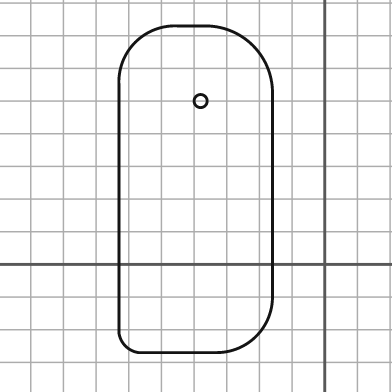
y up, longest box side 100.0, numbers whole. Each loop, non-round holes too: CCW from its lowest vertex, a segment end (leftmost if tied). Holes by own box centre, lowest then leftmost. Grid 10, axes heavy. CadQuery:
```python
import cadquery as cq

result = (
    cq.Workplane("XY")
    .moveTo(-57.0, -27.0)
    .lineTo(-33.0, -27.0)
    .threePointArc((-21.0, -22.0), (-16.0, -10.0))
    .lineTo(-16.0, 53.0)
    .threePointArc((-22.0, 67.0), (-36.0, 73.0))
    .lineTo(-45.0, 73.0)
    .threePointArc((-58.0, 68.0), (-63.0, 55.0))
    .lineTo(-63.0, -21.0)
    .threePointArc((-61.0, -25.0), (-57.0, -27.0))
    .close()
    .moveTo(-38.0, 50.0)
    .circle(2.0)
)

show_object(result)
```